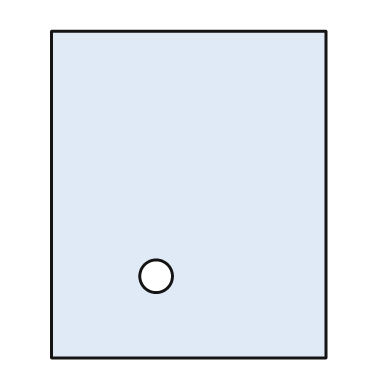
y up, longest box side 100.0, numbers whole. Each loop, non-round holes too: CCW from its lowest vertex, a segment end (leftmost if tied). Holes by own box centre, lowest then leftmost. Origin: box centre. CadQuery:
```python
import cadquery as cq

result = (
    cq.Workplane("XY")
    .moveTo(-42.0, -50.0)
    .lineTo(42.0, -50.0)
    .lineTo(42.0, 50.0)
    .lineTo(-42.0, 50.0)
    .close()
    .moveTo(-10.0, -25.0)
    .circle(5.0)
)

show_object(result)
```